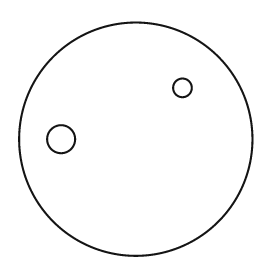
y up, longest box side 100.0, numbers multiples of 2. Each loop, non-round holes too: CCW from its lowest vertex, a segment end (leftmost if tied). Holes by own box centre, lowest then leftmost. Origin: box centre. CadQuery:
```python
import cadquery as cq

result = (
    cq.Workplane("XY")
    .moveTo(0.0, 0.0)
    .circle(50.0)
    .moveTo(-32.0, 0.0)
    .circle(6.0)
    .moveTo(20.0, 22.0)
    .circle(4.0)
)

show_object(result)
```